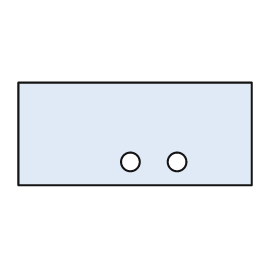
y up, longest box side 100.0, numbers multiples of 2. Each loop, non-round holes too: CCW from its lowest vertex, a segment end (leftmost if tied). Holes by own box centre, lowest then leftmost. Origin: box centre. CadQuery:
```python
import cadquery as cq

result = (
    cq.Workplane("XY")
    .moveTo(-50.0, -22.0)
    .lineTo(50.0, -22.0)
    .lineTo(50.0, 22.0)
    .lineTo(-50.0, 22.0)
    .close()
    .moveTo(-2.0, -12.0)
    .circle(4.0)
    .moveTo(18.0, -12.0)
    .circle(4.0)
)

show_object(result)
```